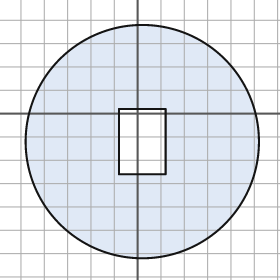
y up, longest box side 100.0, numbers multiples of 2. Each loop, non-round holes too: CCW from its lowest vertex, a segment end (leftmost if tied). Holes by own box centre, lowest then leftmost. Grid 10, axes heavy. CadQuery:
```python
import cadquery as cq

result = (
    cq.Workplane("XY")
    .moveTo(2.0, -12.0)
    .circle(50.0)
    .moveTo(-8.0, -26.0)
    .lineTo(12.0, -26.0)
    .lineTo(12.0, 2.0)
    .lineTo(-8.0, 2.0)
    .close()
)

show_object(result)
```